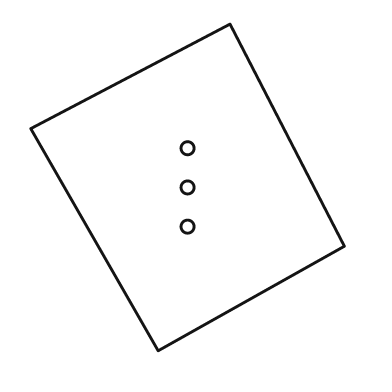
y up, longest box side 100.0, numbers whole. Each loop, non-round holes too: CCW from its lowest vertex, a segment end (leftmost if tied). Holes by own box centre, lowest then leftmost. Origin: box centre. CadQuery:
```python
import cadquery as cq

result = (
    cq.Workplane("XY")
    .moveTo(-9.0, -50.0)
    .lineTo(48.0, -18.0)
    .lineTo(13.0, 50.0)
    .lineTo(-48.0, 18.0)
    .close()
    .moveTo(0.0, -12.0)
    .circle(2.0)
    .moveTo(0.0, 0.0)
    .circle(2.0)
    .moveTo(0.0, 12.0)
    .circle(2.0)
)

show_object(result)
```